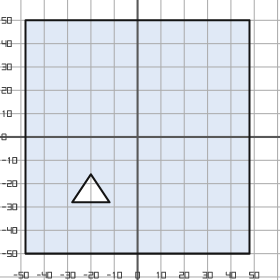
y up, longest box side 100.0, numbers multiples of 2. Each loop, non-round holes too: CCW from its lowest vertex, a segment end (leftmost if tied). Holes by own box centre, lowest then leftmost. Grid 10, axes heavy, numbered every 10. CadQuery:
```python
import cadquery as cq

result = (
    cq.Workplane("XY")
    .moveTo(-48.0, -50.0)
    .lineTo(48.0, -50.0)
    .lineTo(48.0, 50.0)
    .lineTo(-48.0, 50.0)
    .close()
    .moveTo(-28.0, -28.0)
    .lineTo(-12.0, -28.0)
    .lineTo(-20.0, -16.0)
    .close()
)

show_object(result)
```